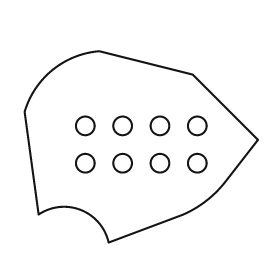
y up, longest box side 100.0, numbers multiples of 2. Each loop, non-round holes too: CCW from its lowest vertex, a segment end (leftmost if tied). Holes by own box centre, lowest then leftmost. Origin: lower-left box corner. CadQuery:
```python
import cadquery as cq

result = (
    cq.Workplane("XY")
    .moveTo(36.0, 0.0)
    .lineTo(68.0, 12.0)
    .threePointArc((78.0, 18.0), (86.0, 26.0))
    .lineTo(100.0, 44.0)
    .lineTo(72.0, 72.0)
    .lineTo(32.0, 82.0)
    .threePointArc((12.0, 74.0), (0.0, 56.0))
    .lineTo(6.0, 12.0)
    .threePointArc((24.0, 14.0), (36.0, 0.0))
    .close()
    .moveTo(26.0, 34.0)
    .circle(4.0)
    .moveTo(42.0, 34.0)
    .circle(4.0)
    .moveTo(58.0, 34.0)
    .circle(4.0)
    .moveTo(74.0, 34.0)
    .circle(4.0)
    .moveTo(26.0, 50.0)
    .circle(4.0)
    .moveTo(42.0, 50.0)
    .circle(4.0)
    .moveTo(58.0, 50.0)
    .circle(4.0)
    .moveTo(74.0, 50.0)
    .circle(4.0)
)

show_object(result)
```